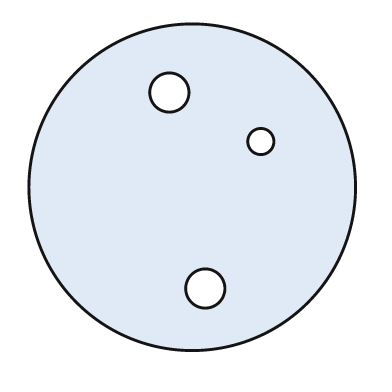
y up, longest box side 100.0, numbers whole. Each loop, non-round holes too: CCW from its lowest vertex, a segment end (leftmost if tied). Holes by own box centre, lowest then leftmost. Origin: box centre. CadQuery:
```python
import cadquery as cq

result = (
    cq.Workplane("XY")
    .moveTo(0.0, 0.0)
    .circle(50.0)
    .moveTo(4.0, -31.0)
    .circle(6.0)
    .moveTo(21.0, 14.0)
    .circle(4.0)
    .moveTo(-7.0, 29.0)
    .circle(6.0)
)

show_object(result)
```